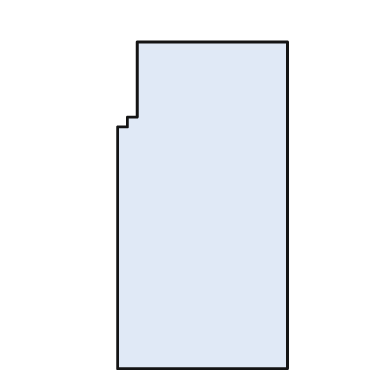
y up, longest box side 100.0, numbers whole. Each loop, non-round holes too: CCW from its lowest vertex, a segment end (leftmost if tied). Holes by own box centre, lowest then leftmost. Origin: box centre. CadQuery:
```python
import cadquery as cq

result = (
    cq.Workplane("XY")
    .moveTo(-26.0, -50.0)
    .lineTo(26.0, -50.0)
    .lineTo(26.0, 50.0)
    .lineTo(-20.0, 50.0)
    .lineTo(-20.0, 27.0)
    .lineTo(-23.0, 27.0)
    .lineTo(-23.0, 24.0)
    .lineTo(-26.0, 24.0)
    .close()
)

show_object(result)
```